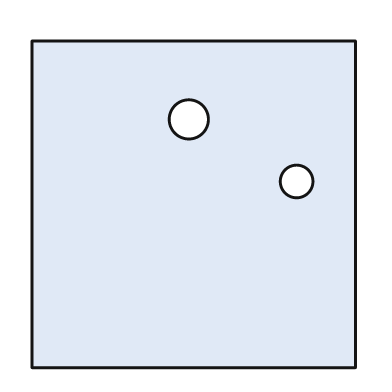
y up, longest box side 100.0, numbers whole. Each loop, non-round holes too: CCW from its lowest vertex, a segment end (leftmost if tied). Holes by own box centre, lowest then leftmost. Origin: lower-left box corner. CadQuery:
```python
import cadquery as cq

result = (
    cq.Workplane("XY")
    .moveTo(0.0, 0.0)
    .lineTo(99.0, 0.0)
    .lineTo(99.0, 100.0)
    .lineTo(0.0, 100.0)
    .close()
    .moveTo(81.0, 57.0)
    .circle(5.0)
    .moveTo(48.0, 76.0)
    .circle(6.0)
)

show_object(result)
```